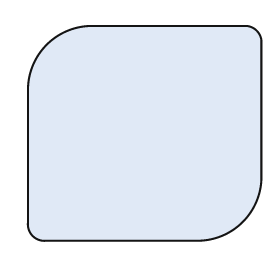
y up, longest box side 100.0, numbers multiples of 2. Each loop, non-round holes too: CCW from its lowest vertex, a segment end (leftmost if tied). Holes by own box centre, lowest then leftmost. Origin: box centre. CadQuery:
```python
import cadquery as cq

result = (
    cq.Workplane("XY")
    .moveTo(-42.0, -46.0)
    .lineTo(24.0, -46.0)
    .threePointArc((42.0, -38.0), (50.0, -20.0))
    .lineTo(50.0, 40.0)
    .threePointArc((48.0, 44.0), (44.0, 46.0))
    .lineTo(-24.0, 46.0)
    .threePointArc((-42.0, 38.0), (-50.0, 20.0))
    .lineTo(-50.0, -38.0)
    .threePointArc((-48.0, -44.0), (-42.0, -46.0))
    .close()
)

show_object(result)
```